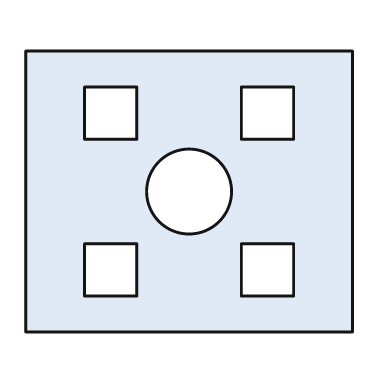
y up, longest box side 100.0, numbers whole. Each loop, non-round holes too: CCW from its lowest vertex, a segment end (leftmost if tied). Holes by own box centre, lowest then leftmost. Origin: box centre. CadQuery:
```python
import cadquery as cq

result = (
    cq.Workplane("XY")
    .moveTo(-50.0, -43.0)
    .lineTo(50.0, -43.0)
    .lineTo(50.0, 43.0)
    .lineTo(-50.0, 43.0)
    .close()
    .moveTo(-32.0, -32.0)
    .lineTo(-16.0, -32.0)
    .lineTo(-16.0, -16.0)
    .lineTo(-32.0, -16.0)
    .close()
    .moveTo(16.0, -32.0)
    .lineTo(32.0, -32.0)
    .lineTo(32.0, -16.0)
    .lineTo(16.0, -16.0)
    .close()
    .moveTo(0.0, 0.0)
    .circle(13.0)
    .moveTo(-32.0, 16.0)
    .lineTo(-16.0, 16.0)
    .lineTo(-16.0, 32.0)
    .lineTo(-32.0, 32.0)
    .close()
    .moveTo(16.0, 16.0)
    .lineTo(32.0, 16.0)
    .lineTo(32.0, 32.0)
    .lineTo(16.0, 32.0)
    .close()
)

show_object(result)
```